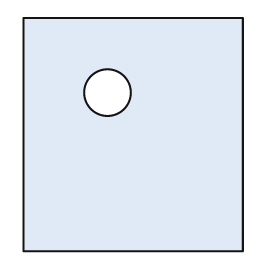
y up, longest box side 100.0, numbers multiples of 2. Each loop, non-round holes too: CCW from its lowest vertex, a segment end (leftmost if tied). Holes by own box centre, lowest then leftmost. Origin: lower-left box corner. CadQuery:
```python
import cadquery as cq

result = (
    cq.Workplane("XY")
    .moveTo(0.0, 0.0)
    .lineTo(94.0, 0.0)
    .lineTo(94.0, 100.0)
    .lineTo(0.0, 100.0)
    .close()
    .moveTo(36.0, 68.0)
    .circle(10.0)
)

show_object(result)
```